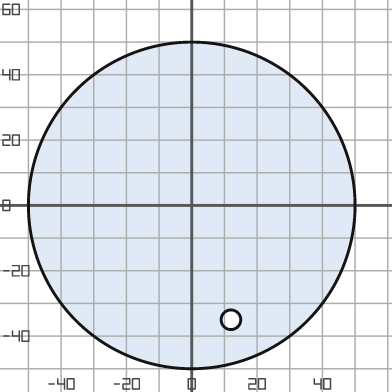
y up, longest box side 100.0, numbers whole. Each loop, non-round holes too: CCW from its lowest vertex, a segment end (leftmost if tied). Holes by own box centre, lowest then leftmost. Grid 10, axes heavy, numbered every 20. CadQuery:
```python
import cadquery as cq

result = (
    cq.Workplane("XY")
    .moveTo(0.0, 0.0)
    .circle(50.0)
    .moveTo(12.0, -35.0)
    .circle(3.0)
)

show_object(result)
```